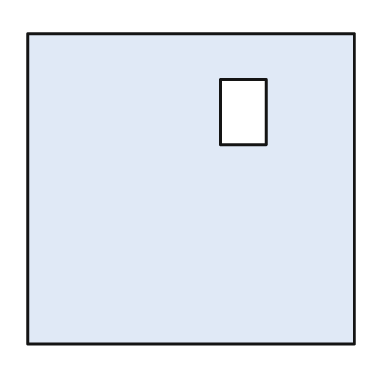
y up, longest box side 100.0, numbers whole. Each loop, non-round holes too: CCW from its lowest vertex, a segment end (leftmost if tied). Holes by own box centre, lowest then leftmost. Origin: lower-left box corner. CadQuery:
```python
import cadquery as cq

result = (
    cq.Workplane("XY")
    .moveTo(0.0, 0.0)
    .lineTo(100.0, 0.0)
    .lineTo(100.0, 95.0)
    .lineTo(0.0, 95.0)
    .close()
    .moveTo(59.0, 61.0)
    .lineTo(73.0, 61.0)
    .lineTo(73.0, 81.0)
    .lineTo(59.0, 81.0)
    .close()
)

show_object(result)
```